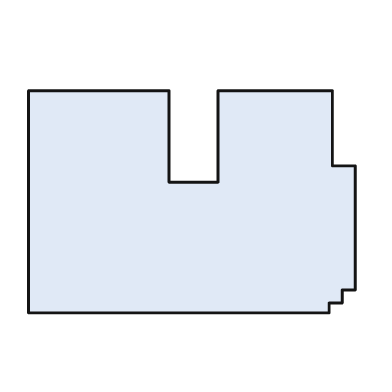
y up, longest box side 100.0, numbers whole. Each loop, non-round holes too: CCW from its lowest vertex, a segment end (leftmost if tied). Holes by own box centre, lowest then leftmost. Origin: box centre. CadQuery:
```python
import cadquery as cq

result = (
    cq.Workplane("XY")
    .moveTo(-50.0, -34.0)
    .lineTo(42.0, -34.0)
    .lineTo(42.0, -31.0)
    .lineTo(46.0, -31.0)
    .lineTo(46.0, -27.0)
    .lineTo(50.0, -27.0)
    .lineTo(50.0, 11.0)
    .lineTo(43.0, 11.0)
    .lineTo(43.0, 34.0)
    .lineTo(8.0, 34.0)
    .lineTo(8.0, 6.0)
    .lineTo(-7.0, 6.0)
    .lineTo(-7.0, 34.0)
    .lineTo(-50.0, 34.0)
    .close()
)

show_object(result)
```